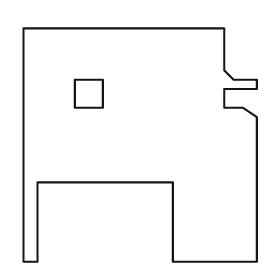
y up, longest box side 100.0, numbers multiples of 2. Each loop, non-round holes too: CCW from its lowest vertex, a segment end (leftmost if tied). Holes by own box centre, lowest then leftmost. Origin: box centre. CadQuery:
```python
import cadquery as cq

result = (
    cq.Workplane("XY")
    .moveTo(-50.0, -50.0)
    .lineTo(-44.0, -50.0)
    .lineTo(-44.0, -16.0)
    .lineTo(14.0, -16.0)
    .lineTo(14.0, -50.0)
    .lineTo(50.0, -50.0)
    .lineTo(50.0, 12.0)
    .lineTo(44.0, 16.0)
    .lineTo(36.0, 16.0)
    .lineTo(36.0, 24.0)
    .lineTo(50.0, 24.0)
    .lineTo(50.0, 28.0)
    .lineTo(40.0, 28.0)
    .lineTo(36.0, 32.0)
    .lineTo(36.0, 50.0)
    .lineTo(-50.0, 50.0)
    .close()
    .moveTo(-28.0, 16.0)
    .lineTo(-16.0, 16.0)
    .lineTo(-16.0, 28.0)
    .lineTo(-28.0, 28.0)
    .close()
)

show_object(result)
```